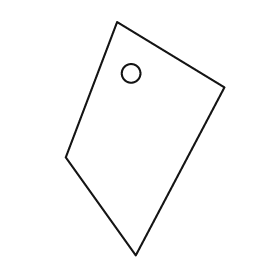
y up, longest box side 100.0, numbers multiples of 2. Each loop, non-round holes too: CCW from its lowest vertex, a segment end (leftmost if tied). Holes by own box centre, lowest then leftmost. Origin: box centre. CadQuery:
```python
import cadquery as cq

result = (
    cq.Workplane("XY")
    .moveTo(-4.0, -50.0)
    .lineTo(34.0, 22.0)
    .lineTo(-12.0, 50.0)
    .lineTo(-34.0, -8.0)
    .close()
    .moveTo(-6.0, 28.0)
    .circle(4.0)
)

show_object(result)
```